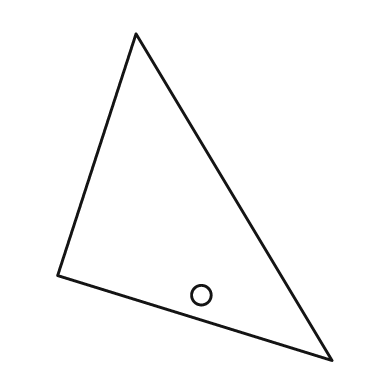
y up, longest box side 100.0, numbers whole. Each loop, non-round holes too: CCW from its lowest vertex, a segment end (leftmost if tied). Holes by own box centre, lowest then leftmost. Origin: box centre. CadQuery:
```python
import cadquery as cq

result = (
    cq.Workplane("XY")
    .moveTo(42.0, -50.0)
    .lineTo(-18.0, 50.0)
    .lineTo(-42.0, -24.0)
    .close()
    .moveTo(2.0, -30.0)
    .circle(3.0)
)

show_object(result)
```